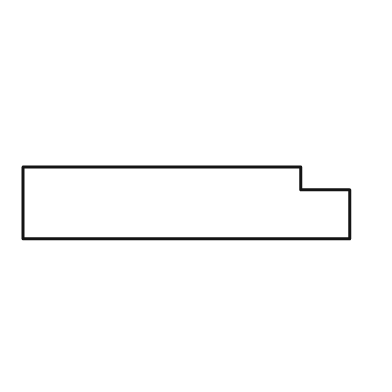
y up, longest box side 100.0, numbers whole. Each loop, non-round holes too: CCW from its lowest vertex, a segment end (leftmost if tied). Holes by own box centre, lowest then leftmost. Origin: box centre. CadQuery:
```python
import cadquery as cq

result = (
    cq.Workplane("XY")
    .moveTo(-50.0, -11.0)
    .lineTo(50.0, -11.0)
    .lineTo(50.0, 4.0)
    .lineTo(35.0, 4.0)
    .lineTo(35.0, 11.0)
    .lineTo(-50.0, 11.0)
    .close()
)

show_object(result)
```